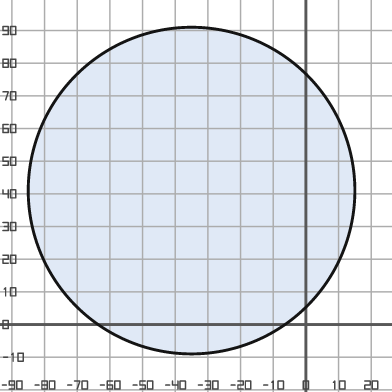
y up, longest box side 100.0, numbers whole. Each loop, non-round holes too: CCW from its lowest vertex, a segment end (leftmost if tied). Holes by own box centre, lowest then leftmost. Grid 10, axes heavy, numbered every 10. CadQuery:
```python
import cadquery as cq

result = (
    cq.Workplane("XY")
    .moveTo(-35.0, 41.0)
    .circle(50.0)
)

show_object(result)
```